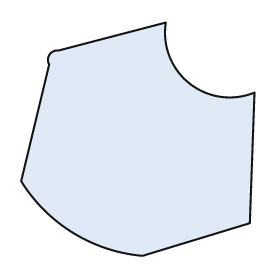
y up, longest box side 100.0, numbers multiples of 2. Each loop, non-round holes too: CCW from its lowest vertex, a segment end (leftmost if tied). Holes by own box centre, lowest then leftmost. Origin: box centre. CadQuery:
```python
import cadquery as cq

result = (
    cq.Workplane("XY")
    .moveTo(2.0, -50.0)
    .lineTo(48.0, -36.0)
    .lineTo(50.0, 20.0)
    .threePointArc((22.0, 24.0), (12.0, 50.0))
    .lineTo(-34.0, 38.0)
    .threePointArc((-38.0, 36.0), (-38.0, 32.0))
    .lineTo(-50.0, -18.0)
    .threePointArc((-28.0, -40.0), (2.0, -50.0))
    .close()
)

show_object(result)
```